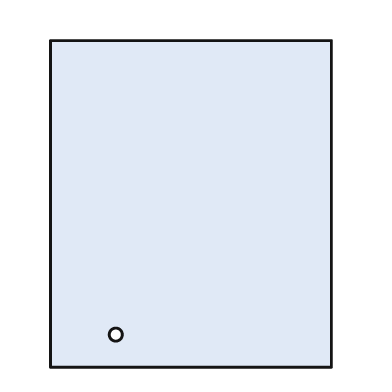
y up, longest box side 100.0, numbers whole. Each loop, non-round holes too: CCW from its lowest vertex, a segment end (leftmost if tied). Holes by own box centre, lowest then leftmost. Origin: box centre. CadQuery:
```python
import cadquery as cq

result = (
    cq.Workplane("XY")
    .moveTo(-43.0, -50.0)
    .lineTo(43.0, -50.0)
    .lineTo(43.0, 50.0)
    .lineTo(-43.0, 50.0)
    .close()
    .moveTo(-23.0, -40.0)
    .circle(2.0)
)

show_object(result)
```